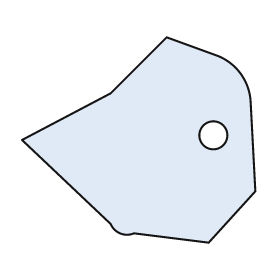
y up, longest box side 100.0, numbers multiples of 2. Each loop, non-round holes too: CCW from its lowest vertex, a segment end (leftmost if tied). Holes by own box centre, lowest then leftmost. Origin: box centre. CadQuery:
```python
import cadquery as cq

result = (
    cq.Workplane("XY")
    .moveTo(30.0, -44.0)
    .lineTo(50.0, -22.0)
    .lineTo(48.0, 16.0)
    .threePointArc((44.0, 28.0), (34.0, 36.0))
    .lineTo(12.0, 44.0)
    .lineTo(-12.0, 20.0)
    .lineTo(-50.0, 0.0)
    .lineTo(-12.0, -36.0)
    .threePointArc((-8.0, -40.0), (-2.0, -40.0))
    .close()
    .moveTo(32.0, 2.0)
    .circle(6.0)
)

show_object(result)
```